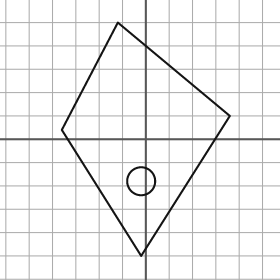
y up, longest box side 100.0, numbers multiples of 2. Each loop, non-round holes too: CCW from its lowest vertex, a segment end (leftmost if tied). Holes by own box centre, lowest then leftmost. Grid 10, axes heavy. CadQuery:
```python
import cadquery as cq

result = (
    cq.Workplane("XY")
    .moveTo(-2.0, -50.0)
    .lineTo(36.0, 10.0)
    .lineTo(-12.0, 50.0)
    .lineTo(-36.0, 4.0)
    .close()
    .moveTo(-2.0, -18.0)
    .circle(6.0)
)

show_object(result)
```